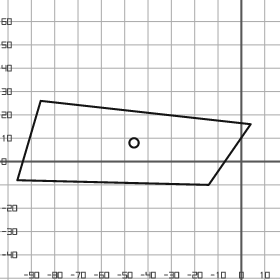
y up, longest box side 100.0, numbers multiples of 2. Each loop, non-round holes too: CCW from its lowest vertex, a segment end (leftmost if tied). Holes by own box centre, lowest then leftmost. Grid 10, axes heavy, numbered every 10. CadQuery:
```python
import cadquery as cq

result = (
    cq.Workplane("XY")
    .moveTo(-14.0, -10.0)
    .lineTo(4.0, 16.0)
    .lineTo(-86.0, 26.0)
    .lineTo(-96.0, -8.0)
    .close()
    .moveTo(-46.0, 8.0)
    .circle(2.0)
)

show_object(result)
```